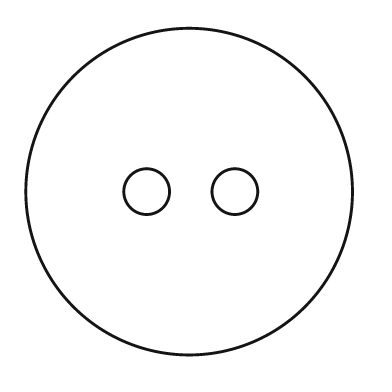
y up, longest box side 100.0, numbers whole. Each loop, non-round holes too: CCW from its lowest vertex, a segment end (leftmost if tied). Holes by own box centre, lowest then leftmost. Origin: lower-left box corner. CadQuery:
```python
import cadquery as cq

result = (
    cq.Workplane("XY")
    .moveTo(50.0, 50.0)
    .circle(50.0)
    .moveTo(37.0, 50.0)
    .circle(7.0)
    .moveTo(64.0, 50.0)
    .circle(7.0)
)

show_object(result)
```